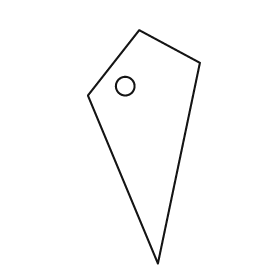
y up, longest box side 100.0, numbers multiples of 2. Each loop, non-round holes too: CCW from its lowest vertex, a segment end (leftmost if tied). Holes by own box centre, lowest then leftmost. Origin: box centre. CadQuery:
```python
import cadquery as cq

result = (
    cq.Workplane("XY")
    .moveTo(6.0, -50.0)
    .lineTo(24.0, 36.0)
    .lineTo(-2.0, 50.0)
    .lineTo(-24.0, 22.0)
    .close()
    .moveTo(-8.0, 26.0)
    .circle(4.0)
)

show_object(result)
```